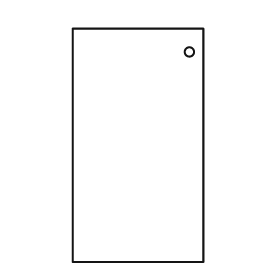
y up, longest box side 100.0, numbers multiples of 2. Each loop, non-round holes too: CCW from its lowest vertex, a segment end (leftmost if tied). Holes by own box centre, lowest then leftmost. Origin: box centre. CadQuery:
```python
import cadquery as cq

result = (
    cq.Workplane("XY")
    .moveTo(-28.0, -50.0)
    .lineTo(28.0, -50.0)
    .lineTo(28.0, 50.0)
    .lineTo(-28.0, 50.0)
    .close()
    .moveTo(22.0, 40.0)
    .circle(2.0)
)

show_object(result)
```